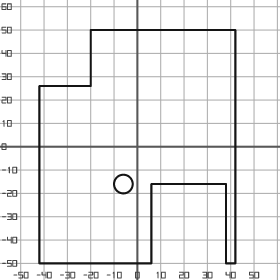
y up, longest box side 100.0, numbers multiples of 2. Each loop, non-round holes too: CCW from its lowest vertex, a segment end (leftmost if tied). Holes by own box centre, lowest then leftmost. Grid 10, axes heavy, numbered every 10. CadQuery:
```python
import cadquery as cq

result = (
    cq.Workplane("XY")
    .moveTo(-42.0, -50.0)
    .lineTo(6.0, -50.0)
    .lineTo(6.0, -16.0)
    .lineTo(38.0, -16.0)
    .lineTo(38.0, -50.0)
    .lineTo(42.0, -50.0)
    .lineTo(42.0, 50.0)
    .lineTo(-20.0, 50.0)
    .lineTo(-20.0, 26.0)
    .lineTo(-42.0, 26.0)
    .close()
    .moveTo(-6.0, -16.0)
    .circle(4.0)
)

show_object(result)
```